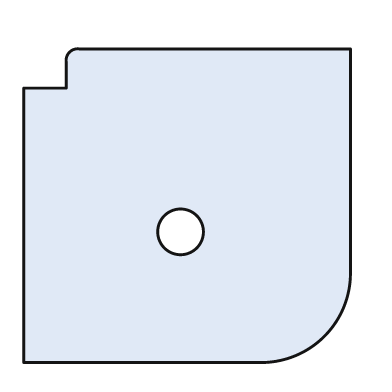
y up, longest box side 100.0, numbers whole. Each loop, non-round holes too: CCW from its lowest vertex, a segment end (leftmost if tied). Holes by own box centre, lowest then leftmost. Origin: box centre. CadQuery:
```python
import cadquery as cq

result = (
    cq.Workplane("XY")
    .moveTo(-50.0, -48.0)
    .lineTo(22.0, -48.0)
    .threePointArc((42.0, -40.0), (50.0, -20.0))
    .lineTo(50.0, 48.0)
    .lineTo(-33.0, 48.0)
    .threePointArc((-36.0, 47.0), (-37.0, 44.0))
    .lineTo(-37.0, 36.0)
    .lineTo(-50.0, 36.0)
    .close()
    .moveTo(-2.0, -8.0)
    .circle(7.0)
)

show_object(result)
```